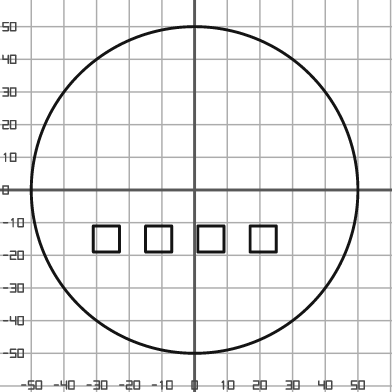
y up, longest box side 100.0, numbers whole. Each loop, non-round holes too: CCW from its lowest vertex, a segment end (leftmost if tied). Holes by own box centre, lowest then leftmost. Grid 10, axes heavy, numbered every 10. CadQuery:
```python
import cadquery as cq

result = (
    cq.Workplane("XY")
    .moveTo(0.0, 0.0)
    .circle(50.0)
    .moveTo(-31.0, -19.0)
    .lineTo(-23.0, -19.0)
    .lineTo(-23.0, -11.0)
    .lineTo(-31.0, -11.0)
    .close()
    .moveTo(-15.0, -19.0)
    .lineTo(-7.0, -19.0)
    .lineTo(-7.0, -11.0)
    .lineTo(-15.0, -11.0)
    .close()
    .moveTo(1.0, -19.0)
    .lineTo(9.0, -19.0)
    .lineTo(9.0, -11.0)
    .lineTo(1.0, -11.0)
    .close()
    .moveTo(17.0, -19.0)
    .lineTo(25.0, -19.0)
    .lineTo(25.0, -11.0)
    .lineTo(17.0, -11.0)
    .close()
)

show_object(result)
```